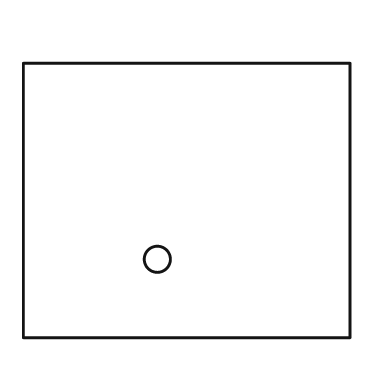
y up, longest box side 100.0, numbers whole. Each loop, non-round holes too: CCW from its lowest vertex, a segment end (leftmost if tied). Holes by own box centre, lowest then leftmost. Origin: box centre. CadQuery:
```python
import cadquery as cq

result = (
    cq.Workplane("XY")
    .moveTo(-50.0, -42.0)
    .lineTo(50.0, -42.0)
    .lineTo(50.0, 42.0)
    .lineTo(-50.0, 42.0)
    .close()
    .moveTo(-9.0, -18.0)
    .circle(4.0)
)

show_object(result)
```